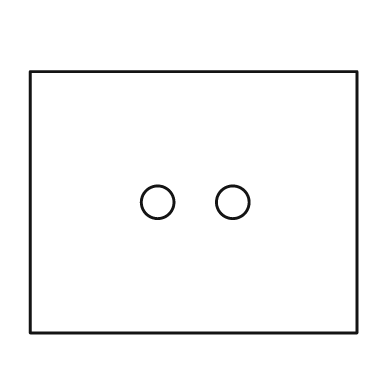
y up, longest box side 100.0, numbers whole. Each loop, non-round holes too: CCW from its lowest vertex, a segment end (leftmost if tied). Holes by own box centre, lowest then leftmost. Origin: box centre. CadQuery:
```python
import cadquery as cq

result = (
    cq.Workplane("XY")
    .moveTo(-50.0, -40.0)
    .lineTo(50.0, -40.0)
    .lineTo(50.0, 40.0)
    .lineTo(-50.0, 40.0)
    .close()
    .moveTo(-11.0, 0.0)
    .circle(5.0)
    .moveTo(12.0, 0.0)
    .circle(5.0)
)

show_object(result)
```